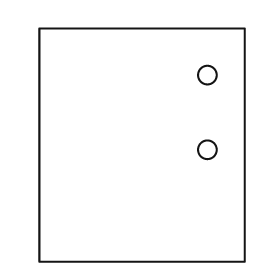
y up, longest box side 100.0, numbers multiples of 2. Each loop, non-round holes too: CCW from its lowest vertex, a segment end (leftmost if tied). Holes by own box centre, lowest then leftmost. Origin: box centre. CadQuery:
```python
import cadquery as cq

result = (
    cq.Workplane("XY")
    .moveTo(-44.0, -50.0)
    .lineTo(44.0, -50.0)
    .lineTo(44.0, 50.0)
    .lineTo(-44.0, 50.0)
    .close()
    .moveTo(28.0, -2.0)
    .circle(4.0)
    .moveTo(28.0, 30.0)
    .circle(4.0)
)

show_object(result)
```